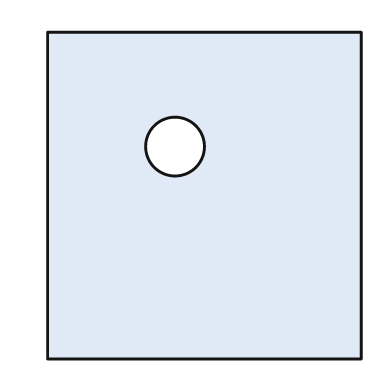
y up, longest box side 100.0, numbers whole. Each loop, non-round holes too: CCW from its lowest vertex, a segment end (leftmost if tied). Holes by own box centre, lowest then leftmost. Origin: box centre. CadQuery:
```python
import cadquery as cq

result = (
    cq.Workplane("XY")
    .moveTo(-48.0, -50.0)
    .lineTo(48.0, -50.0)
    .lineTo(48.0, 50.0)
    .lineTo(-48.0, 50.0)
    .close()
    .moveTo(-9.0, 15.0)
    .circle(9.0)
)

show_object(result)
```